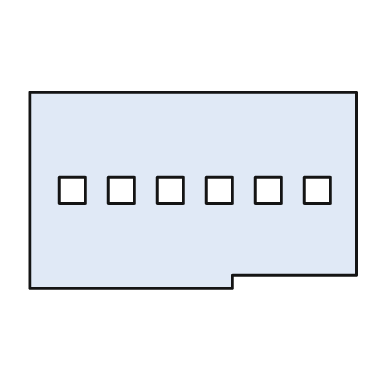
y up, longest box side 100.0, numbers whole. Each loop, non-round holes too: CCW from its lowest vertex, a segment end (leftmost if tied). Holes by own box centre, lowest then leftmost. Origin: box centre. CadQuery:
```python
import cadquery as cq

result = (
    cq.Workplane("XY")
    .moveTo(-50.0, -30.0)
    .lineTo(12.0, -30.0)
    .lineTo(12.0, -26.0)
    .lineTo(50.0, -26.0)
    .lineTo(50.0, 30.0)
    .lineTo(-50.0, 30.0)
    .close()
    .moveTo(-41.0, -4.0)
    .lineTo(-33.0, -4.0)
    .lineTo(-33.0, 4.0)
    .lineTo(-41.0, 4.0)
    .close()
    .moveTo(-26.0, -4.0)
    .lineTo(-18.0, -4.0)
    .lineTo(-18.0, 4.0)
    .lineTo(-26.0, 4.0)
    .close()
    .moveTo(-11.0, -4.0)
    .lineTo(-3.0, -4.0)
    .lineTo(-3.0, 4.0)
    .lineTo(-11.0, 4.0)
    .close()
    .moveTo(4.0, -4.0)
    .lineTo(12.0, -4.0)
    .lineTo(12.0, 4.0)
    .lineTo(4.0, 4.0)
    .close()
    .moveTo(19.0, -4.0)
    .lineTo(27.0, -4.0)
    .lineTo(27.0, 4.0)
    .lineTo(19.0, 4.0)
    .close()
    .moveTo(34.0, -4.0)
    .lineTo(42.0, -4.0)
    .lineTo(42.0, 4.0)
    .lineTo(34.0, 4.0)
    .close()
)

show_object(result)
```